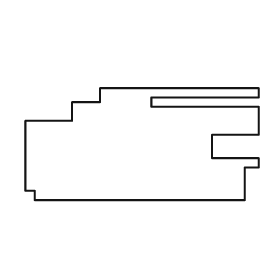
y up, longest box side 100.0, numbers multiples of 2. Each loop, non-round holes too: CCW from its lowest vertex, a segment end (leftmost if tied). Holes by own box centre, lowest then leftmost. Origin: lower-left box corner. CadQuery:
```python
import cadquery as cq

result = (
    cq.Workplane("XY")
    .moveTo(4.0, 0.0)
    .lineTo(94.0, 0.0)
    .lineTo(94.0, 14.0)
    .lineTo(100.0, 14.0)
    .lineTo(100.0, 18.0)
    .lineTo(80.0, 18.0)
    .lineTo(80.0, 28.0)
    .lineTo(100.0, 28.0)
    .lineTo(100.0, 40.0)
    .lineTo(54.0, 40.0)
    .lineTo(54.0, 44.0)
    .lineTo(100.0, 44.0)
    .lineTo(100.0, 48.0)
    .lineTo(32.0, 48.0)
    .lineTo(32.0, 42.0)
    .lineTo(20.0, 42.0)
    .lineTo(20.0, 34.0)
    .lineTo(0.0, 34.0)
    .lineTo(0.0, 4.0)
    .lineTo(4.0, 4.0)
    .close()
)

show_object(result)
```